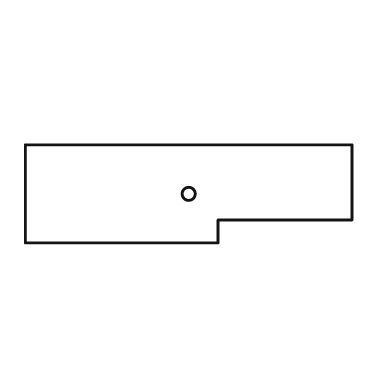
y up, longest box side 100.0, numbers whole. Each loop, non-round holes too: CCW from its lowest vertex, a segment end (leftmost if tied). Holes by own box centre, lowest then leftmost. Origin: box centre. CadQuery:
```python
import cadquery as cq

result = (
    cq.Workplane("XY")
    .moveTo(-50.0, -15.0)
    .lineTo(9.0, -15.0)
    .lineTo(9.0, -8.0)
    .lineTo(50.0, -8.0)
    .lineTo(50.0, 15.0)
    .lineTo(-50.0, 15.0)
    .close()
    .moveTo(0.0, 0.0)
    .circle(2.0)
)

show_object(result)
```